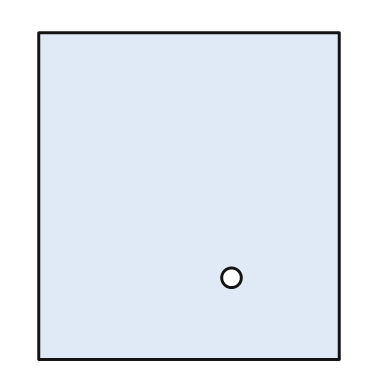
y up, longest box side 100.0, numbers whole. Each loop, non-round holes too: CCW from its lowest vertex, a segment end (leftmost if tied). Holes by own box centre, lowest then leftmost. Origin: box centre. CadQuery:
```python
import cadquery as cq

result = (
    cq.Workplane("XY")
    .moveTo(-46.0, -50.0)
    .lineTo(46.0, -50.0)
    .lineTo(46.0, 50.0)
    .lineTo(-46.0, 50.0)
    .close()
    .moveTo(13.0, -25.0)
    .circle(3.0)
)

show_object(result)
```